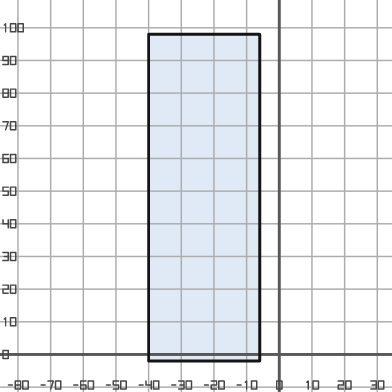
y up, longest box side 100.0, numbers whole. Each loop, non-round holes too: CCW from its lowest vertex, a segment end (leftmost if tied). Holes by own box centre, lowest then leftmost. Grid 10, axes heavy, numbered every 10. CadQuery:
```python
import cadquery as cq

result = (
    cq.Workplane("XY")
    .moveTo(-40.0, -2.0)
    .lineTo(-6.0, -2.0)
    .lineTo(-6.0, 98.0)
    .lineTo(-40.0, 98.0)
    .close()
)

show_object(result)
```